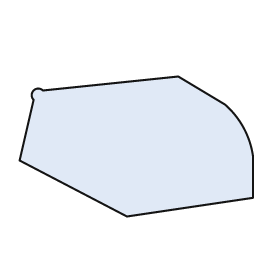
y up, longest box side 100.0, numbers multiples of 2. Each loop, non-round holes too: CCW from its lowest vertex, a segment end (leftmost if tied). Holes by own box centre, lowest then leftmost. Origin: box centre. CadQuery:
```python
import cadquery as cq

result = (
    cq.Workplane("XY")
    .moveTo(-4.0, -30.0)
    .lineTo(50.0, -22.0)
    .lineTo(50.0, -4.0)
    .threePointArc((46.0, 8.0), (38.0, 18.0))
    .lineTo(18.0, 30.0)
    .lineTo(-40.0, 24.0)
    .threePointArc((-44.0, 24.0), (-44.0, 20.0))
    .lineTo(-50.0, -6.0)
    .close()
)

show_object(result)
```